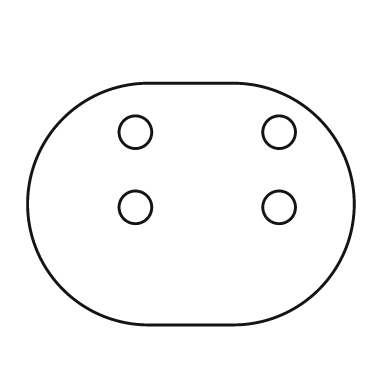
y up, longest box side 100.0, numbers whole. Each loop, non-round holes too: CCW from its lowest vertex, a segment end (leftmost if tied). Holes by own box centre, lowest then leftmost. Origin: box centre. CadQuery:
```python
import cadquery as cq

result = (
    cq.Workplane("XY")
    .moveTo(-13.0, -37.0)
    .lineTo(13.0, -37.0)
    .threePointArc((50.0, 0.0), (13.0, 37.0))
    .lineTo(-13.0, 37.0)
    .threePointArc((-50.0, 0.0), (-13.0, -37.0))
    .close()
    .moveTo(-17.0, -1.0)
    .circle(5.0)
    .moveTo(27.0, -1.0)
    .circle(5.0)
    .moveTo(-17.0, 22.0)
    .circle(5.0)
    .moveTo(27.0, 22.0)
    .circle(5.0)
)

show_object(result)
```